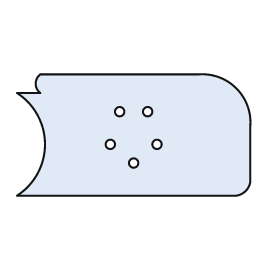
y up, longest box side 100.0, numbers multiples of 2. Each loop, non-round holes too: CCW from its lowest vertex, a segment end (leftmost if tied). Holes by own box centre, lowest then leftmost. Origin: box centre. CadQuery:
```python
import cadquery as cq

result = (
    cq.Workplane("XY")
    .moveTo(-50.0, -26.0)
    .lineTo(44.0, -26.0)
    .threePointArc((48.0, -24.0), (50.0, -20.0))
    .lineTo(50.0, 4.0)
    .threePointArc((44.0, 20.0), (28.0, 26.0))
    .lineTo(-40.0, 26.0)
    .threePointArc((-42.0, 22.0), (-40.0, 18.0))
    .lineTo(-50.0, 18.0)
    .threePointArc((-38.0, -4.0), (-50.0, -26.0))
    .close()
    .moveTo(0.0, -12.0)
    .circle(2.0)
    .moveTo(-10.0, -4.0)
    .circle(2.0)
    .moveTo(10.0, -4.0)
    .circle(2.0)
    .moveTo(-6.0, 10.0)
    .circle(2.0)
    .moveTo(6.0, 10.0)
    .circle(2.0)
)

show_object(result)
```